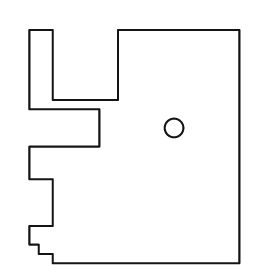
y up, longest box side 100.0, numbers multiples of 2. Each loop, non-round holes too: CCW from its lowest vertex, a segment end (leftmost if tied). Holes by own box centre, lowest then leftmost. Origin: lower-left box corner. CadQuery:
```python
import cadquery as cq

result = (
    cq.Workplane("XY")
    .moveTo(10.0, 0.0)
    .lineTo(90.0, 0.0)
    .lineTo(90.0, 100.0)
    .lineTo(38.0, 100.0)
    .lineTo(38.0, 70.0)
    .lineTo(10.0, 70.0)
    .lineTo(10.0, 100.0)
    .lineTo(0.0, 100.0)
    .lineTo(0.0, 66.0)
    .lineTo(30.0, 66.0)
    .lineTo(30.0, 50.0)
    .lineTo(0.0, 50.0)
    .lineTo(0.0, 36.0)
    .lineTo(10.0, 36.0)
    .lineTo(10.0, 16.0)
    .lineTo(0.0, 16.0)
    .lineTo(0.0, 8.0)
    .lineTo(4.0, 8.0)
    .lineTo(4.0, 4.0)
    .lineTo(10.0, 4.0)
    .close()
    .moveTo(62.0, 58.0)
    .circle(4.0)
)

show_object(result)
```